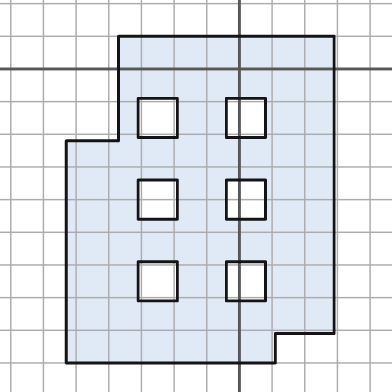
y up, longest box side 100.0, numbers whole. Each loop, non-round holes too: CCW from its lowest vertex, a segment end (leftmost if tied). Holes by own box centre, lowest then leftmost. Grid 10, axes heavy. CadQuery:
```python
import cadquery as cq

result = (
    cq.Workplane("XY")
    .moveTo(-53.0, -90.0)
    .lineTo(11.0, -90.0)
    .lineTo(11.0, -81.0)
    .lineTo(29.0, -81.0)
    .lineTo(29.0, 10.0)
    .lineTo(-37.0, 10.0)
    .lineTo(-37.0, -22.0)
    .lineTo(-53.0, -22.0)
    .close()
    .moveTo(-31.0, -71.0)
    .lineTo(-19.0, -71.0)
    .lineTo(-19.0, -59.0)
    .lineTo(-31.0, -59.0)
    .close()
    .moveTo(-4.0, -71.0)
    .lineTo(8.0, -71.0)
    .lineTo(8.0, -59.0)
    .lineTo(-4.0, -59.0)
    .close()
    .moveTo(-31.0, -46.0)
    .lineTo(-19.0, -46.0)
    .lineTo(-19.0, -34.0)
    .lineTo(-31.0, -34.0)
    .close()
    .moveTo(-4.0, -46.0)
    .lineTo(8.0, -46.0)
    .lineTo(8.0, -34.0)
    .lineTo(-4.0, -34.0)
    .close()
    .moveTo(-31.0, -21.0)
    .lineTo(-19.0, -21.0)
    .lineTo(-19.0, -9.0)
    .lineTo(-31.0, -9.0)
    .close()
    .moveTo(-4.0, -21.0)
    .lineTo(8.0, -21.0)
    .lineTo(8.0, -9.0)
    .lineTo(-4.0, -9.0)
    .close()
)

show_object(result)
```